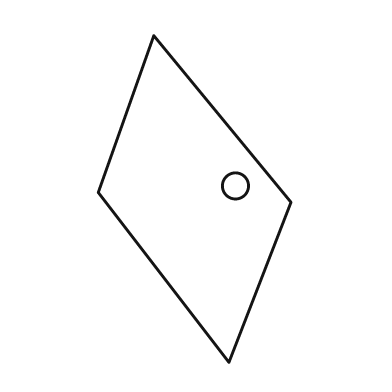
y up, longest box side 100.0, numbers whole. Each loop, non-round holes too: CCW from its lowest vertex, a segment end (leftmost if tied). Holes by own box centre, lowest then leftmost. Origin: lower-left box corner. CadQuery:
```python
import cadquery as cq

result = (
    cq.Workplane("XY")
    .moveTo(40.0, 0.0)
    .lineTo(59.0, 49.0)
    .lineTo(17.0, 100.0)
    .lineTo(0.0, 52.0)
    .close()
    .moveTo(42.0, 54.0)
    .circle(4.0)
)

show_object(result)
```